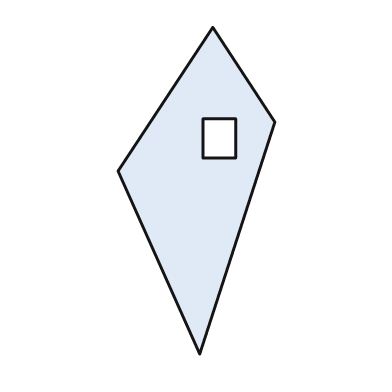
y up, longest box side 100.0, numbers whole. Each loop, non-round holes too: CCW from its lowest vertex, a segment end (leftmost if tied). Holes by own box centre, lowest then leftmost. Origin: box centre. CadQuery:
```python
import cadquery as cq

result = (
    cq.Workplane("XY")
    .moveTo(1.0, -50.0)
    .lineTo(24.0, 21.0)
    .lineTo(5.0, 50.0)
    .lineTo(-24.0, 6.0)
    .close()
    .moveTo(2.0, 10.0)
    .lineTo(12.0, 10.0)
    .lineTo(12.0, 22.0)
    .lineTo(2.0, 22.0)
    .close()
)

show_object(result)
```